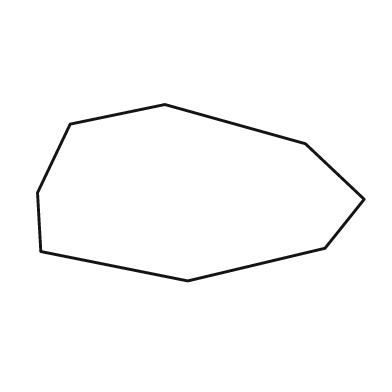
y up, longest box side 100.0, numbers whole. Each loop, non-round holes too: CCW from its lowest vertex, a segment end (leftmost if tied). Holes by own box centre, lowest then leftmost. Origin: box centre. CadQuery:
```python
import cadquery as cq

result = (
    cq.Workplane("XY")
    .moveTo(-4.0, -27.0)
    .lineTo(38.0, -17.0)
    .lineTo(50.0, -2.0)
    .lineTo(32.0, 15.0)
    .lineTo(-11.0, 27.0)
    .lineTo(-40.0, 21.0)
    .lineTo(-50.0, 0.0)
    .lineTo(-49.0, -18.0)
    .close()
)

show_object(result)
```